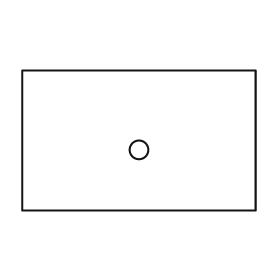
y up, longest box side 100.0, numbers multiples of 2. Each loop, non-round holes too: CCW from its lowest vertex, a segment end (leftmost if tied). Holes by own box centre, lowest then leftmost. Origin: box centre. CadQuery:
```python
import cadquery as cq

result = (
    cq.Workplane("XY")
    .moveTo(-50.0, -30.0)
    .lineTo(50.0, -30.0)
    .lineTo(50.0, 30.0)
    .lineTo(-50.0, 30.0)
    .close()
    .moveTo(0.0, -4.0)
    .circle(4.0)
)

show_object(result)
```